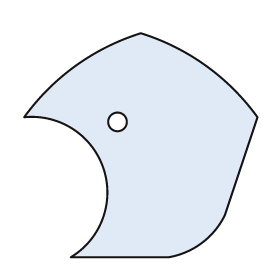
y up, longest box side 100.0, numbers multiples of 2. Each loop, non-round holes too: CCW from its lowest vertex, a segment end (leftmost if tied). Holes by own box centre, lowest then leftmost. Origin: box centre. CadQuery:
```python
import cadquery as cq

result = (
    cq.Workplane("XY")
    .moveTo(-30.0, -48.0)
    .lineTo(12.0, -48.0)
    .threePointArc((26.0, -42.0), (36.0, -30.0))
    .lineTo(50.0, 12.0)
    .threePointArc((28.0, 34.0), (0.0, 48.0))
    .threePointArc((-28.0, 34.0), (-50.0, 12.0))
    .threePointArc((-16.0, -10.0), (-30.0, -48.0))
    .close()
    .moveTo(-10.0, 10.0)
    .circle(4.0)
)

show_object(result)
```